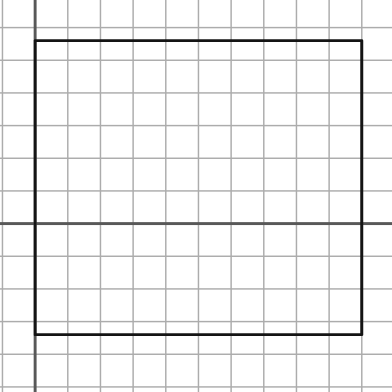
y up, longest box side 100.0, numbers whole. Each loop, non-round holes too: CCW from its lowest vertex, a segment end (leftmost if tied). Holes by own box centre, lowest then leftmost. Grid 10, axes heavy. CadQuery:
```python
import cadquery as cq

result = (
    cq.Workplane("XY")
    .moveTo(0.0, -34.0)
    .lineTo(100.0, -34.0)
    .lineTo(100.0, 56.0)
    .lineTo(0.0, 56.0)
    .close()
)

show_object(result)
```